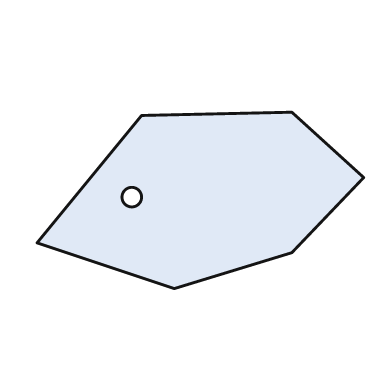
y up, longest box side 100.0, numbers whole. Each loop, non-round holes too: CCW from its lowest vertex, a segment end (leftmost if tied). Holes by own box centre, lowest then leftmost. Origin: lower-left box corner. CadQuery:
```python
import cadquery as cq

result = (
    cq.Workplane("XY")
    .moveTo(42.0, 0.0)
    .lineTo(78.0, 11.0)
    .lineTo(100.0, 34.0)
    .lineTo(78.0, 54.0)
    .lineTo(32.0, 53.0)
    .lineTo(0.0, 14.0)
    .close()
    .moveTo(29.0, 28.0)
    .circle(3.0)
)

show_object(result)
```